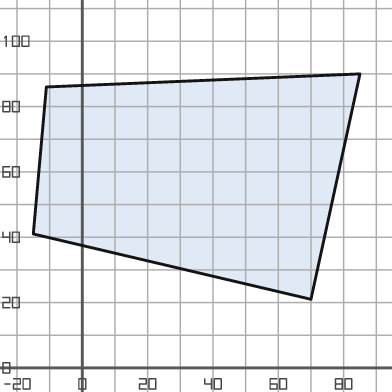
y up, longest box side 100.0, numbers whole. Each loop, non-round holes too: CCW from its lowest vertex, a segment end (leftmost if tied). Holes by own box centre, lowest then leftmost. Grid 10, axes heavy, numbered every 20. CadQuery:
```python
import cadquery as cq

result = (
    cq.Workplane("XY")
    .moveTo(70.0, 21.0)
    .lineTo(85.0, 90.0)
    .lineTo(-11.0, 86.0)
    .lineTo(-15.0, 41.0)
    .close()
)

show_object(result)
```